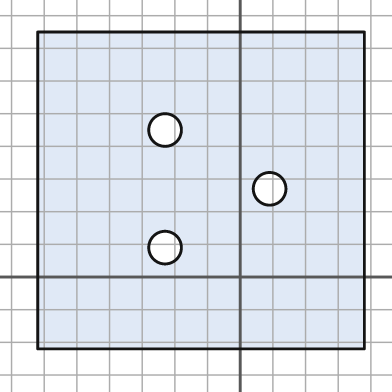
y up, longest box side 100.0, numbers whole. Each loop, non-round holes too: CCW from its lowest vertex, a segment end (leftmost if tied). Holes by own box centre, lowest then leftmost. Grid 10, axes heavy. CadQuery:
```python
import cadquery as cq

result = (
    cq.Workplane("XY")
    .moveTo(-62.0, -22.0)
    .lineTo(38.0, -22.0)
    .lineTo(38.0, 75.0)
    .lineTo(-62.0, 75.0)
    .close()
    .moveTo(-23.0, 9.0)
    .circle(5.0)
    .moveTo(9.0, 27.0)
    .circle(5.0)
    .moveTo(-23.0, 45.0)
    .circle(5.0)
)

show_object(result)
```